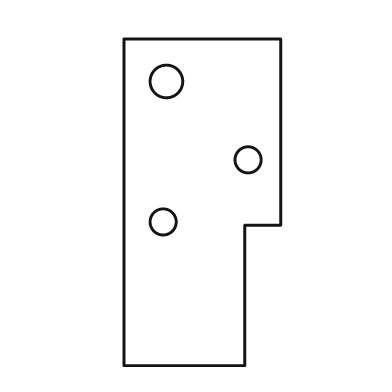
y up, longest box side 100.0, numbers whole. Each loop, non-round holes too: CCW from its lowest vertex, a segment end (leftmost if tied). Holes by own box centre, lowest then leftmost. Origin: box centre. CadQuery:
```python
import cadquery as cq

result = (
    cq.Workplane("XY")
    .moveTo(-24.0, -50.0)
    .lineTo(13.0, -50.0)
    .lineTo(13.0, -7.0)
    .lineTo(24.0, -7.0)
    .lineTo(24.0, 50.0)
    .lineTo(-24.0, 50.0)
    .close()
    .moveTo(-12.0, -6.0)
    .circle(4.0)
    .moveTo(14.0, 13.0)
    .circle(4.0)
    .moveTo(-11.0, 37.0)
    .circle(5.0)
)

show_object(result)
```